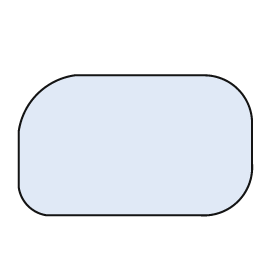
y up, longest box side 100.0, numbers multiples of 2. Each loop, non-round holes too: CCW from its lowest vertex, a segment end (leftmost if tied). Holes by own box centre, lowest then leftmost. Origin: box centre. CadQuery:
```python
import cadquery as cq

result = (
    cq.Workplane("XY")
    .moveTo(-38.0, -30.0)
    .lineTo(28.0, -30.0)
    .threePointArc((44.0, -24.0), (50.0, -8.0))
    .lineTo(50.0, 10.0)
    .threePointArc((44.0, 24.0), (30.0, 30.0))
    .lineTo(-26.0, 30.0)
    .threePointArc((-42.0, 22.0), (-50.0, 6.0))
    .lineTo(-50.0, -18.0)
    .threePointArc((-46.0, -26.0), (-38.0, -30.0))
    .close()
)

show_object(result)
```